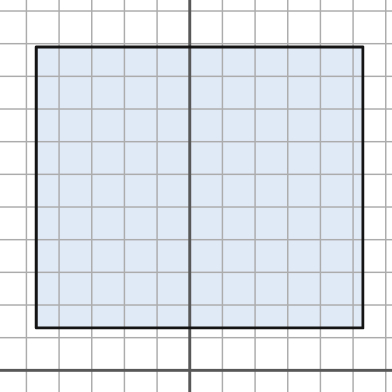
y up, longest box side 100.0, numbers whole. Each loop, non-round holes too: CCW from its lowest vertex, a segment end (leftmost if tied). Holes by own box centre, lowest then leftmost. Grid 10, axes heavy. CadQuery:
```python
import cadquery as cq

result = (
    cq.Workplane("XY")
    .moveTo(-47.0, 13.0)
    .lineTo(53.0, 13.0)
    .lineTo(53.0, 99.0)
    .lineTo(-47.0, 99.0)
    .close()
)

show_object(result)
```